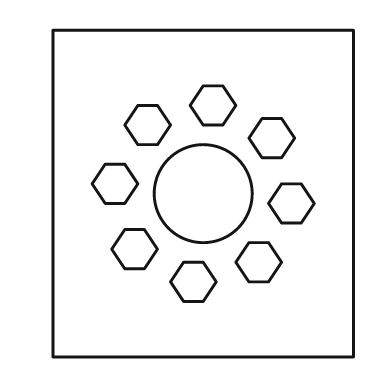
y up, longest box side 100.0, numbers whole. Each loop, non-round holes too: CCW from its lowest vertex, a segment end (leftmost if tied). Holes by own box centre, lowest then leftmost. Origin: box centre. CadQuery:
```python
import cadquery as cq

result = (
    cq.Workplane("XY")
    .moveTo(-46.0, -50.0)
    .lineTo(46.0, -50.0)
    .lineTo(46.0, 50.0)
    .lineTo(-46.0, 50.0)
    .close()
    .moveTo(-6.0, -33.0)
    .lineTo(0.0, -33.0)
    .lineTo(4.0, -27.0)
    .lineTo(0.0, -21.0)
    .lineTo(-6.0, -21.0)
    .lineTo(-10.0, -27.0)
    .close()
    .moveTo(14.0, -27.0)
    .lineTo(20.0, -27.0)
    .lineTo(24.0, -21.0)
    .lineTo(20.0, -15.0)
    .lineTo(14.0, -15.0)
    .lineTo(10.0, -21.0)
    .close()
    .moveTo(-24.0, -23.0)
    .lineTo(-18.0, -23.0)
    .lineTo(-14.0, -17.0)
    .lineTo(-18.0, -11.0)
    .lineTo(-24.0, -11.0)
    .lineTo(-28.0, -17.0)
    .close()
    .moveTo(24.0, -9.0)
    .lineTo(30.0, -9.0)
    .lineTo(34.0, -3.0)
    .lineTo(30.0, 3.0)
    .lineTo(24.0, 3.0)
    .lineTo(20.0, -3.0)
    .close()
    .moveTo(0.0, 0.0)
    .circle(15.0)
    .moveTo(-30.0, -3.0)
    .lineTo(-24.0, -3.0)
    .lineTo(-20.0, 3.0)
    .lineTo(-24.0, 9.0)
    .lineTo(-30.0, 9.0)
    .lineTo(-34.0, 3.0)
    .close()
    .moveTo(18.0, 11.0)
    .lineTo(24.0, 11.0)
    .lineTo(28.0, 17.0)
    .lineTo(24.0, 23.0)
    .lineTo(18.0, 23.0)
    .lineTo(14.0, 17.0)
    .close()
    .moveTo(-20.0, 15.0)
    .lineTo(-14.0, 15.0)
    .lineTo(-10.0, 21.0)
    .lineTo(-14.0, 27.0)
    .lineTo(-20.0, 27.0)
    .lineTo(-24.0, 21.0)
    .close()
    .moveTo(0.0, 21.0)
    .lineTo(6.0, 21.0)
    .lineTo(10.0, 27.0)
    .lineTo(6.0, 33.0)
    .lineTo(0.0, 33.0)
    .lineTo(-4.0, 27.0)
    .close()
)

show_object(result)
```